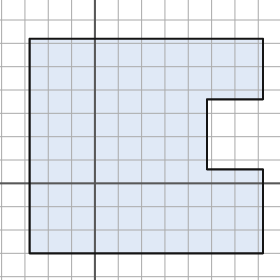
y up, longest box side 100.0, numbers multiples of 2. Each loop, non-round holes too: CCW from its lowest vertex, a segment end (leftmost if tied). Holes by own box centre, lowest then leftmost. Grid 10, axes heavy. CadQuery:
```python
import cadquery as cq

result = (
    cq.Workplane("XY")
    .moveTo(-28.0, -30.0)
    .lineTo(72.0, -30.0)
    .lineTo(72.0, 6.0)
    .lineTo(48.0, 6.0)
    .lineTo(48.0, 36.0)
    .lineTo(72.0, 36.0)
    .lineTo(72.0, 62.0)
    .lineTo(-28.0, 62.0)
    .close()
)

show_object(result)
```